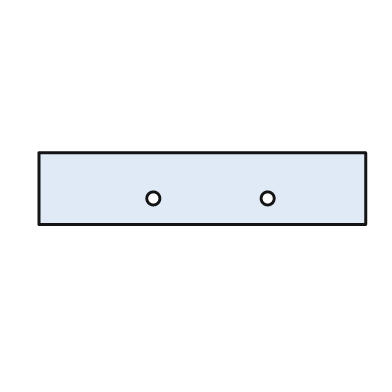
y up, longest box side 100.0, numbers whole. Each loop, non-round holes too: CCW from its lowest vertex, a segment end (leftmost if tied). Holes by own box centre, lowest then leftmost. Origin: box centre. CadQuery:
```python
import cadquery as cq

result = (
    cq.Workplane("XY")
    .moveTo(-50.0, -11.0)
    .lineTo(50.0, -11.0)
    .lineTo(50.0, 11.0)
    .lineTo(-50.0, 11.0)
    .close()
    .moveTo(-15.0, -3.0)
    .circle(2.0)
    .moveTo(20.0, -3.0)
    .circle(2.0)
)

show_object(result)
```